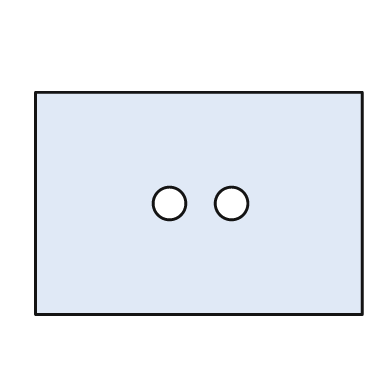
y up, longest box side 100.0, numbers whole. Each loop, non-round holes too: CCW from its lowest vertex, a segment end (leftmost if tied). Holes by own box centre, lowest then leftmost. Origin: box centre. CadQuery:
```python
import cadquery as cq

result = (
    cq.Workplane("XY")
    .moveTo(-50.0, -34.0)
    .lineTo(50.0, -34.0)
    .lineTo(50.0, 34.0)
    .lineTo(-50.0, 34.0)
    .close()
    .moveTo(-9.0, 0.0)
    .circle(5.0)
    .moveTo(10.0, 0.0)
    .circle(5.0)
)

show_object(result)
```